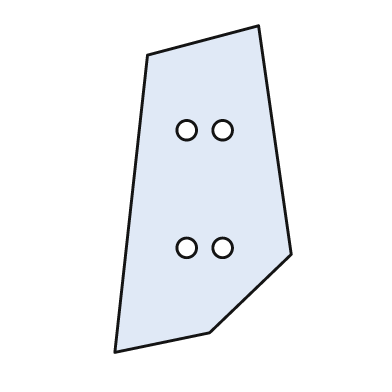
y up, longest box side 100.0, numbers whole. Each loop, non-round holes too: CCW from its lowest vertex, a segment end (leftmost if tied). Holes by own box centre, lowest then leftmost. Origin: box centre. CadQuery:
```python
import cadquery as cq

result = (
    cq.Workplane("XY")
    .moveTo(-27.0, -50.0)
    .lineTo(2.0, -44.0)
    .lineTo(27.0, -20.0)
    .lineTo(17.0, 50.0)
    .lineTo(-17.0, 41.0)
    .close()
    .moveTo(-5.0, -18.0)
    .circle(3.0)
    .moveTo(6.0, -18.0)
    .circle(3.0)
    .moveTo(-5.0, 18.0)
    .circle(3.0)
    .moveTo(6.0, 18.0)
    .circle(3.0)
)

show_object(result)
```